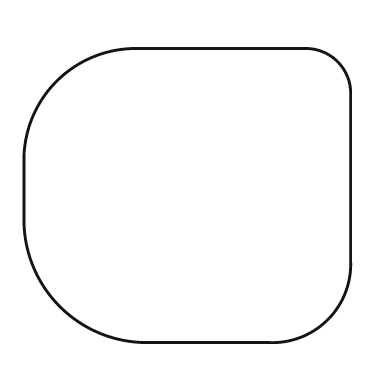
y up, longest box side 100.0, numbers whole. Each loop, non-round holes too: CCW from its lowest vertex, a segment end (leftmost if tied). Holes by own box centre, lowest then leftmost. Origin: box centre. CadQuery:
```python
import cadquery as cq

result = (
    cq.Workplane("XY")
    .moveTo(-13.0, -45.0)
    .lineTo(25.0, -45.0)
    .threePointArc((43.0, -38.0), (50.0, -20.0))
    .lineTo(50.0, 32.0)
    .threePointArc((46.0, 41.0), (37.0, 45.0))
    .lineTo(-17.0, 45.0)
    .threePointArc((-40.0, 35.0), (-50.0, 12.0))
    .lineTo(-50.0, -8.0)
    .threePointArc((-39.0, -34.0), (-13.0, -45.0))
    .close()
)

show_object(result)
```